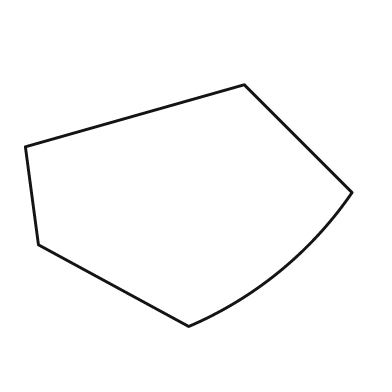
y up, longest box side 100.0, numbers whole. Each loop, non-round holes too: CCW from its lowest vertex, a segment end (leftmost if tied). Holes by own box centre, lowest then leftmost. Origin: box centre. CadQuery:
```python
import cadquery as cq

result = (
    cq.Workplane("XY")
    .moveTo(0.0, -37.0)
    .threePointArc((28.0, -20.0), (50.0, 4.0))
    .lineTo(17.0, 37.0)
    .lineTo(-50.0, 18.0)
    .lineTo(-46.0, -12.0)
    .close()
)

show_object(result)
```